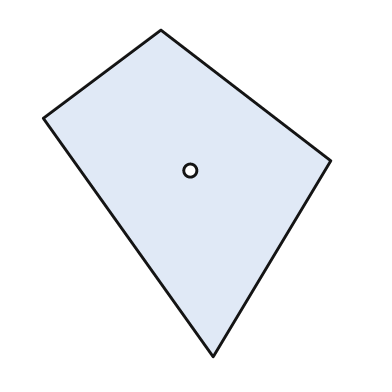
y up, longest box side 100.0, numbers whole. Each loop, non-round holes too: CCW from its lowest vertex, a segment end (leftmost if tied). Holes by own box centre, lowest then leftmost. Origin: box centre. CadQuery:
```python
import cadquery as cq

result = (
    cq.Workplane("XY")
    .moveTo(8.0, -50.0)
    .lineTo(44.0, 10.0)
    .lineTo(-8.0, 50.0)
    .lineTo(-44.0, 23.0)
    .close()
    .moveTo(1.0, 7.0)
    .circle(2.0)
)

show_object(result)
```